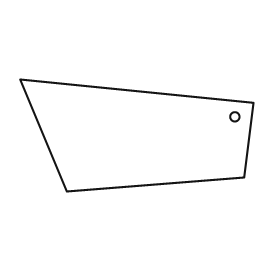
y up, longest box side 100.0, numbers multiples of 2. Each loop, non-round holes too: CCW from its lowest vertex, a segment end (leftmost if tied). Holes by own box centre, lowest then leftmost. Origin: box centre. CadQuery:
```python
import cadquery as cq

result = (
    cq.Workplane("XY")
    .moveTo(-30.0, -24.0)
    .lineTo(46.0, -18.0)
    .lineTo(50.0, 14.0)
    .lineTo(-50.0, 24.0)
    .close()
    .moveTo(42.0, 8.0)
    .circle(2.0)
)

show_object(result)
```